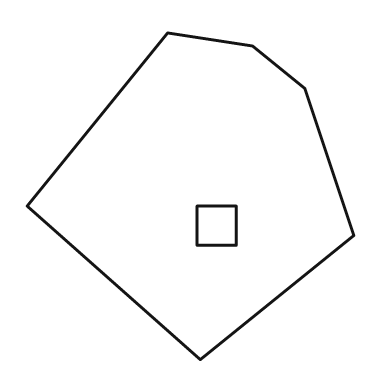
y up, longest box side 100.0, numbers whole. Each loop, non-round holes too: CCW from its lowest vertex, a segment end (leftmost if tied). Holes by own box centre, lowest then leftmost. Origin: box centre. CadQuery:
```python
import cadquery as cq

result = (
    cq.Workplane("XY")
    .moveTo(3.0, -50.0)
    .lineTo(50.0, -12.0)
    .lineTo(35.0, 33.0)
    .lineTo(19.0, 46.0)
    .lineTo(-7.0, 50.0)
    .lineTo(-50.0, -3.0)
    .close()
    .moveTo(2.0, -15.0)
    .lineTo(14.0, -15.0)
    .lineTo(14.0, -3.0)
    .lineTo(2.0, -3.0)
    .close()
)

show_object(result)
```